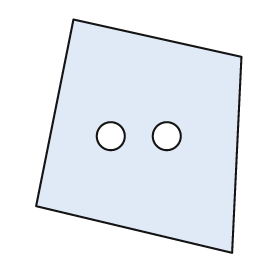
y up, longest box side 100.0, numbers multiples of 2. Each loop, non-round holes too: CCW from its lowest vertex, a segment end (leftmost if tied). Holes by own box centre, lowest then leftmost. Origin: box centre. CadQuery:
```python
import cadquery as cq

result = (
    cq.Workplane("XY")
    .moveTo(40.0, -50.0)
    .lineTo(44.0, 34.0)
    .lineTo(-28.0, 50.0)
    .lineTo(-44.0, -30.0)
    .close()
    .moveTo(-12.0, 0.0)
    .circle(6.0)
    .moveTo(12.0, 0.0)
    .circle(6.0)
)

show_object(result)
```